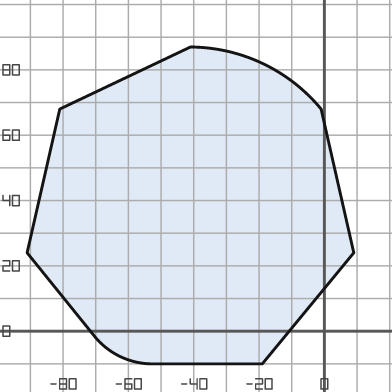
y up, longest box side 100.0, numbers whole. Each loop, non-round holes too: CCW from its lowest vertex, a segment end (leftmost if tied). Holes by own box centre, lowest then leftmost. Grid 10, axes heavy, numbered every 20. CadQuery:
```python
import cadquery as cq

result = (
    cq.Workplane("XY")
    .moveTo(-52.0, -10.0)
    .lineTo(-19.0, -10.0)
    .lineTo(9.0, 24.0)
    .lineTo(-1.0, 68.0)
    .threePointArc((-19.0, 82.0), (-41.0, 87.0))
    .lineTo(-81.0, 68.0)
    .lineTo(-91.0, 24.0)
    .lineTo(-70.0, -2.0)
    .threePointArc((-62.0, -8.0), (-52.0, -10.0))
    .close()
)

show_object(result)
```